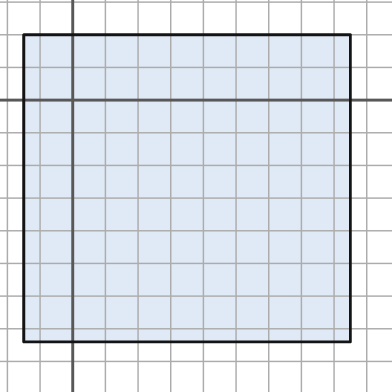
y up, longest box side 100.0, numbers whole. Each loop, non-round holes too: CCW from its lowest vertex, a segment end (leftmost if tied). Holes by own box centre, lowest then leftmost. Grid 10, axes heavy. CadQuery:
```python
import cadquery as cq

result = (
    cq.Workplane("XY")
    .moveTo(-15.0, -74.0)
    .lineTo(85.0, -74.0)
    .lineTo(85.0, 20.0)
    .lineTo(-15.0, 20.0)
    .close()
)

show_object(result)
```